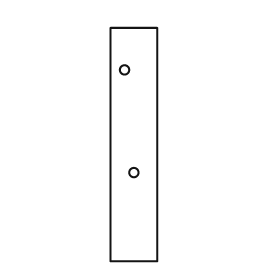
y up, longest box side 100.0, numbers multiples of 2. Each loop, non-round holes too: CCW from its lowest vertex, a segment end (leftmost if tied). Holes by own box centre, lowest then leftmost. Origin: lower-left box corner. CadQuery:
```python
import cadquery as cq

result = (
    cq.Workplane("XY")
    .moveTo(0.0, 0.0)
    .lineTo(20.0, 0.0)
    .lineTo(20.0, 100.0)
    .lineTo(0.0, 100.0)
    .close()
    .moveTo(10.0, 38.0)
    .circle(2.0)
    .moveTo(6.0, 82.0)
    .circle(2.0)
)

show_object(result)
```